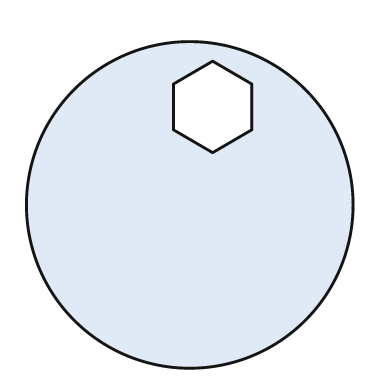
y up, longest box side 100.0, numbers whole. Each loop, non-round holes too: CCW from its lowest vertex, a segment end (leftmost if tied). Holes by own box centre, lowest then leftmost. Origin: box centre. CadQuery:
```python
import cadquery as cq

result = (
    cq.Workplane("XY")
    .moveTo(0.0, 0.0)
    .circle(50.0)
    .moveTo(7.0, 16.0)
    .lineTo(19.0, 23.0)
    .lineTo(19.0, 37.0)
    .lineTo(7.0, 44.0)
    .lineTo(-5.0, 37.0)
    .lineTo(-5.0, 23.0)
    .close()
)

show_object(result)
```